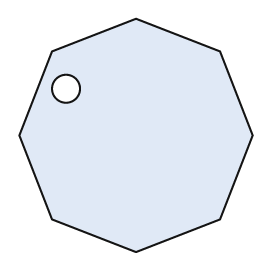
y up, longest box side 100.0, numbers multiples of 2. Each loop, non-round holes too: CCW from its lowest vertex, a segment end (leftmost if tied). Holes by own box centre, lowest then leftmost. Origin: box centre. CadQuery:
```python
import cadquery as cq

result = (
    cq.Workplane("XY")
    .moveTo(0.0, -50.0)
    .lineTo(36.0, -36.0)
    .lineTo(50.0, 0.0)
    .lineTo(36.0, 36.0)
    .lineTo(0.0, 50.0)
    .lineTo(-36.0, 36.0)
    .lineTo(-50.0, 0.0)
    .lineTo(-36.0, -36.0)
    .close()
    .moveTo(-30.0, 20.0)
    .circle(6.0)
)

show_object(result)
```